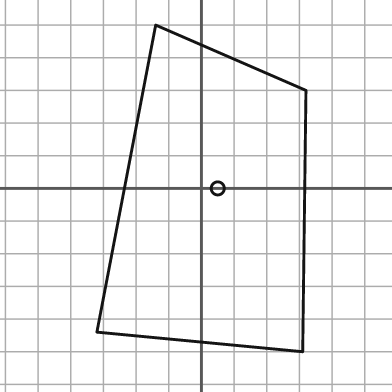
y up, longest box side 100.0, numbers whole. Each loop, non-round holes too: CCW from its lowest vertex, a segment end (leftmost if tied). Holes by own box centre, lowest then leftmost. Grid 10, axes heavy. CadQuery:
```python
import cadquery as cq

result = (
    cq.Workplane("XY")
    .moveTo(31.0, -50.0)
    .lineTo(32.0, 30.0)
    .lineTo(-14.0, 50.0)
    .lineTo(-32.0, -44.0)
    .close()
    .moveTo(5.0, 0.0)
    .circle(2.0)
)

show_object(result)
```